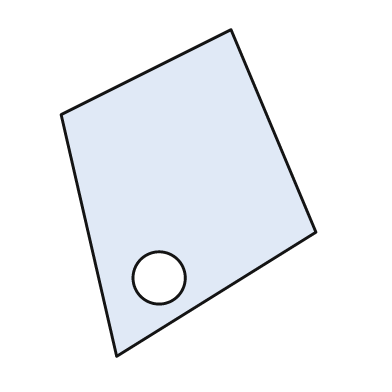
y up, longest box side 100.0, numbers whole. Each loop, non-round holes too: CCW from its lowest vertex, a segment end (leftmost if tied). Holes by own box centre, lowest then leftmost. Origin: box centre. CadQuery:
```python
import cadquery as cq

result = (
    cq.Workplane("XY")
    .moveTo(-22.0, -50.0)
    .lineTo(39.0, -12.0)
    .lineTo(13.0, 50.0)
    .lineTo(-39.0, 24.0)
    .close()
    .moveTo(-9.0, -26.0)
    .circle(8.0)
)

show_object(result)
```